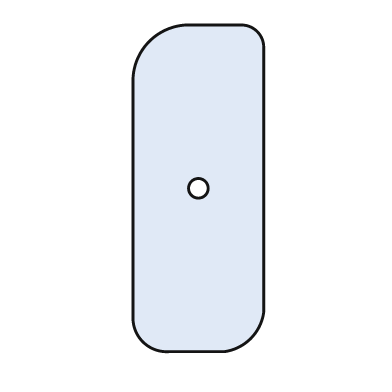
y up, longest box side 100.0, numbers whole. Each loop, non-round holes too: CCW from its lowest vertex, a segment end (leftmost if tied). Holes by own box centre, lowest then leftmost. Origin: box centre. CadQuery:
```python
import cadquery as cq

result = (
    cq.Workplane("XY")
    .moveTo(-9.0, -50.0)
    .lineTo(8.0, -50.0)
    .threePointArc((16.0, -46.0), (20.0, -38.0))
    .lineTo(20.0, 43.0)
    .threePointArc((18.0, 48.0), (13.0, 50.0))
    .lineTo(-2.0, 50.0)
    .threePointArc((-15.0, 45.0), (-20.0, 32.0))
    .lineTo(-20.0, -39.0)
    .threePointArc((-17.0, -47.0), (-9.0, -50.0))
    .close()
    .moveTo(0.0, 0.0)
    .circle(3.0)
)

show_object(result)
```